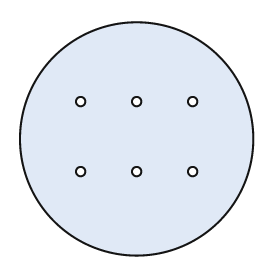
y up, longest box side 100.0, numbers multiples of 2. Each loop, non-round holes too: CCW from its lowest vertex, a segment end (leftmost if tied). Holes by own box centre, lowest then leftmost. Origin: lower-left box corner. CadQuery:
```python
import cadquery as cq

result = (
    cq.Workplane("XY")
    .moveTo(50.0, 50.0)
    .circle(50.0)
    .moveTo(26.0, 36.0)
    .circle(2.0)
    .moveTo(50.0, 36.0)
    .circle(2.0)
    .moveTo(74.0, 36.0)
    .circle(2.0)
    .moveTo(26.0, 66.0)
    .circle(2.0)
    .moveTo(50.0, 66.0)
    .circle(2.0)
    .moveTo(74.0, 66.0)
    .circle(2.0)
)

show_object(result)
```